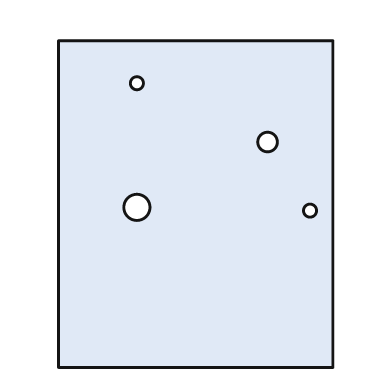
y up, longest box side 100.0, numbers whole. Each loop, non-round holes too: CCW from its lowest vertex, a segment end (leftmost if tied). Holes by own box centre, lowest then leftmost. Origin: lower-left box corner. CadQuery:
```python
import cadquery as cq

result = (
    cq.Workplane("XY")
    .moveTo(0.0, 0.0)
    .lineTo(84.0, 0.0)
    .lineTo(84.0, 100.0)
    .lineTo(0.0, 100.0)
    .close()
    .moveTo(77.0, 48.0)
    .circle(2.0)
    .moveTo(24.0, 49.0)
    .circle(4.0)
    .moveTo(64.0, 69.0)
    .circle(3.0)
    .moveTo(24.0, 87.0)
    .circle(2.0)
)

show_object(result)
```